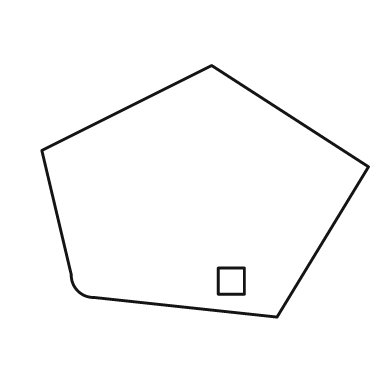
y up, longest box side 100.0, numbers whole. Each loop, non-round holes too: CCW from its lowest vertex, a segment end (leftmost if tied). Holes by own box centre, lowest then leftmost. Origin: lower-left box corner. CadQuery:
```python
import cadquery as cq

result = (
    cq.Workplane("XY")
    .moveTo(72.0, 0.0)
    .lineTo(100.0, 46.0)
    .lineTo(52.0, 77.0)
    .lineTo(0.0, 51.0)
    .lineTo(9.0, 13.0)
    .threePointArc((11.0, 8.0), (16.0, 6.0))
    .close()
    .moveTo(54.0, 7.0)
    .lineTo(62.0, 7.0)
    .lineTo(62.0, 15.0)
    .lineTo(54.0, 15.0)
    .close()
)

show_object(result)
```